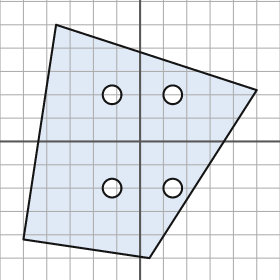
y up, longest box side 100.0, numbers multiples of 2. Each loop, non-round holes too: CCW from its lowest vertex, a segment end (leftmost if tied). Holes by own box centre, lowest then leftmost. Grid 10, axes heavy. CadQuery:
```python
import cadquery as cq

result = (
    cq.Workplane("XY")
    .moveTo(4.0, -50.0)
    .lineTo(50.0, 22.0)
    .lineTo(-36.0, 50.0)
    .lineTo(-50.0, -42.0)
    .close()
    .moveTo(-12.0, -20.0)
    .circle(4.0)
    .moveTo(14.0, -20.0)
    .circle(4.0)
    .moveTo(-12.0, 20.0)
    .circle(4.0)
    .moveTo(14.0, 20.0)
    .circle(4.0)
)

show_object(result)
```